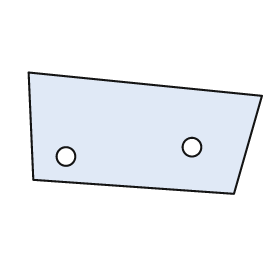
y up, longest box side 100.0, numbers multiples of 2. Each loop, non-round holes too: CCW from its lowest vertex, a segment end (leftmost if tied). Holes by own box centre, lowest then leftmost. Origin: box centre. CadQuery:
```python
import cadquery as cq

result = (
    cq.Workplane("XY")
    .moveTo(38.0, -26.0)
    .lineTo(50.0, 16.0)
    .lineTo(-50.0, 26.0)
    .lineTo(-48.0, -20.0)
    .close()
    .moveTo(-34.0, -10.0)
    .circle(4.0)
    .moveTo(20.0, -6.0)
    .circle(4.0)
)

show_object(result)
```